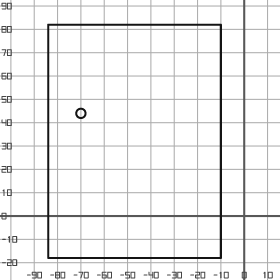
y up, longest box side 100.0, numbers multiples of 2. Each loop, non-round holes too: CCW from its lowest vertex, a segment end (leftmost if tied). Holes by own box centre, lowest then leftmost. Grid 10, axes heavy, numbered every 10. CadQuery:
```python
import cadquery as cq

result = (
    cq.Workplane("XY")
    .moveTo(-84.0, -18.0)
    .lineTo(-10.0, -18.0)
    .lineTo(-10.0, 82.0)
    .lineTo(-84.0, 82.0)
    .close()
    .moveTo(-70.0, 44.0)
    .circle(2.0)
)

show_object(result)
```